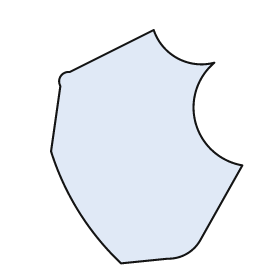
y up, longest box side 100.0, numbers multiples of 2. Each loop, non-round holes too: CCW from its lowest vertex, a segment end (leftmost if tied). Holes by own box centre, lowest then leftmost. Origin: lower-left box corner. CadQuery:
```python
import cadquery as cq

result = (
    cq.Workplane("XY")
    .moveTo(30.0, 0.0)
    .lineTo(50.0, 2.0)
    .threePointArc((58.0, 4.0), (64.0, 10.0))
    .lineTo(82.0, 42.0)
    .threePointArc((62.0, 60.0), (70.0, 86.0))
    .threePointArc((54.0, 88.0), (44.0, 100.0))
    .lineTo(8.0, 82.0)
    .threePointArc((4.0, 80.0), (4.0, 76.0))
    .lineTo(0.0, 48.0)
    .threePointArc((12.0, 22.0), (30.0, 0.0))
    .close()
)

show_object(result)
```